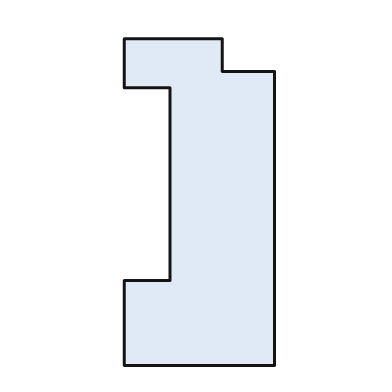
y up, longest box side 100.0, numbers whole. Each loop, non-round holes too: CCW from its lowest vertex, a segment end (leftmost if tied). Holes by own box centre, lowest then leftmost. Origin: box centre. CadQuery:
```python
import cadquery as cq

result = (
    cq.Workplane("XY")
    .moveTo(-23.0, -50.0)
    .lineTo(23.0, -50.0)
    .lineTo(23.0, 40.0)
    .lineTo(7.0, 40.0)
    .lineTo(7.0, 50.0)
    .lineTo(-23.0, 50.0)
    .lineTo(-23.0, 35.0)
    .lineTo(-9.0, 35.0)
    .lineTo(-9.0, -24.0)
    .lineTo(-23.0, -24.0)
    .close()
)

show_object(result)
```